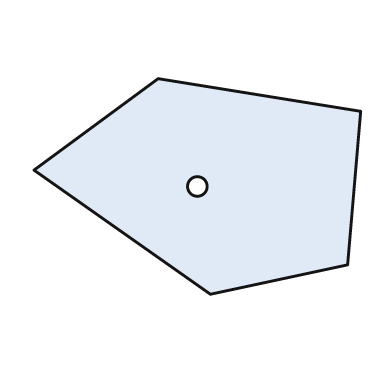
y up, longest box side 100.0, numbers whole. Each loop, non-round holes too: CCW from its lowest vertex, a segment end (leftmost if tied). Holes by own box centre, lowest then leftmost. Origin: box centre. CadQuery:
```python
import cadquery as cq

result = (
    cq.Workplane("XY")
    .moveTo(4.0, -33.0)
    .lineTo(46.0, -24.0)
    .lineTo(50.0, 23.0)
    .lineTo(-12.0, 33.0)
    .lineTo(-50.0, 5.0)
    .close()
    .moveTo(0.0, 0.0)
    .circle(3.0)
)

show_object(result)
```